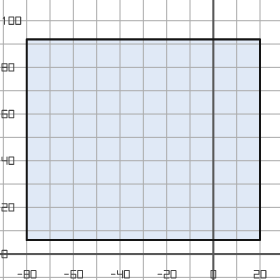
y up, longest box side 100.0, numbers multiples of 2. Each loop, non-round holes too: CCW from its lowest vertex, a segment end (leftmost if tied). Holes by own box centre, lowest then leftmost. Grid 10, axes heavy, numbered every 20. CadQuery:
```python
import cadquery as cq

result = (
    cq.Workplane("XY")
    .moveTo(-80.0, 6.0)
    .lineTo(20.0, 6.0)
    .lineTo(20.0, 92.0)
    .lineTo(-80.0, 92.0)
    .close()
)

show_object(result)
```